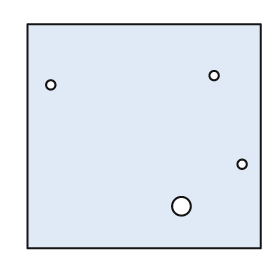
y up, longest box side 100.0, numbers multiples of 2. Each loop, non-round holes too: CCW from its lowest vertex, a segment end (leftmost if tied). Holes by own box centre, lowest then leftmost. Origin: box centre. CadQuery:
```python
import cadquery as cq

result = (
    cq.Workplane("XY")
    .moveTo(-50.0, -48.0)
    .lineTo(50.0, -48.0)
    .lineTo(50.0, 48.0)
    .lineTo(-50.0, 48.0)
    .close()
    .moveTo(16.0, -30.0)
    .circle(4.0)
    .moveTo(42.0, -12.0)
    .circle(2.0)
    .moveTo(-40.0, 22.0)
    .circle(2.0)
    .moveTo(30.0, 26.0)
    .circle(2.0)
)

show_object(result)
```